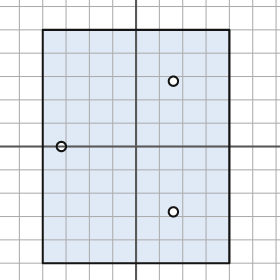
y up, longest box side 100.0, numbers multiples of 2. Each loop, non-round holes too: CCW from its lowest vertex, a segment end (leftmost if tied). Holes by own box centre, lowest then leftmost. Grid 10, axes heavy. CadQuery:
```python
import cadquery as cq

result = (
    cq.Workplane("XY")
    .moveTo(-40.0, -50.0)
    .lineTo(40.0, -50.0)
    .lineTo(40.0, 50.0)
    .lineTo(-40.0, 50.0)
    .close()
    .moveTo(16.0, -28.0)
    .circle(2.0)
    .moveTo(-32.0, 0.0)
    .circle(2.0)
    .moveTo(16.0, 28.0)
    .circle(2.0)
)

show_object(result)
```